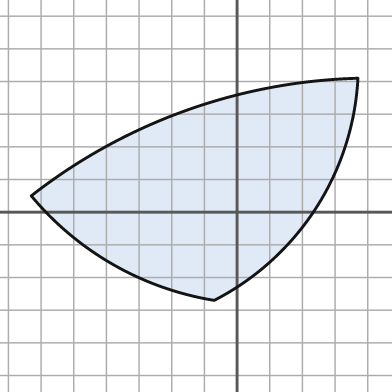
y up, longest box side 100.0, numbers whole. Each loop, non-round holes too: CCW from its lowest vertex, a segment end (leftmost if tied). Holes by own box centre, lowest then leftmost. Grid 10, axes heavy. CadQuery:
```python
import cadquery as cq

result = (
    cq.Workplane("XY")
    .moveTo(-7.0, -27.0)
    .threePointArc((24.0, 1.0), (37.0, 41.0))
    .threePointArc((-16.0, 31.0), (-63.0, 5.0))
    .threePointArc((-38.0, -16.0), (-7.0, -27.0))
    .close()
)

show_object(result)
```